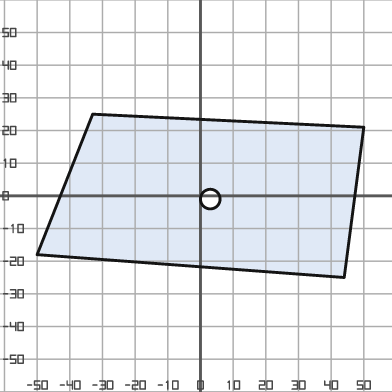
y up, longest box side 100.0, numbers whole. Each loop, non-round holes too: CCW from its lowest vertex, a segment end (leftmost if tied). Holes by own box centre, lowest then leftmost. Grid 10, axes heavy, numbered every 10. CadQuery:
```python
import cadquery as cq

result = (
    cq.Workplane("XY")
    .moveTo(44.0, -25.0)
    .lineTo(50.0, 21.0)
    .lineTo(-33.0, 25.0)
    .lineTo(-50.0, -18.0)
    .close()
    .moveTo(3.0, -1.0)
    .circle(3.0)
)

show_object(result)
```